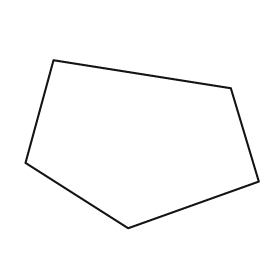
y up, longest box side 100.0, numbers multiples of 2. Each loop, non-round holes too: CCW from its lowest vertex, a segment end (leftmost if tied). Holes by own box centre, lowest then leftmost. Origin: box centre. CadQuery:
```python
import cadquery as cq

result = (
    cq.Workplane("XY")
    .moveTo(-6.0, -36.0)
    .lineTo(50.0, -16.0)
    .lineTo(38.0, 24.0)
    .lineTo(-38.0, 36.0)
    .lineTo(-50.0, -8.0)
    .close()
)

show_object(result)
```